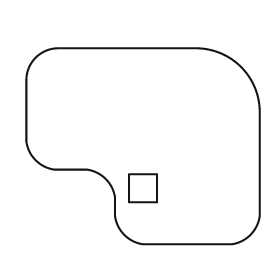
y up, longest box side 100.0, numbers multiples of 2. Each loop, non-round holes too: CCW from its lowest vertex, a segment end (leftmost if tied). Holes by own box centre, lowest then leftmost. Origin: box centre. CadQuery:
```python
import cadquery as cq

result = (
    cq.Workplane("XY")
    .moveTo(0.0, -42.0)
    .lineTo(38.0, -42.0)
    .threePointArc((46.0, -38.0), (50.0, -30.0))
    .lineTo(50.0, 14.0)
    .threePointArc((42.0, 34.0), (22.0, 42.0))
    .lineTo(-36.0, 42.0)
    .threePointArc((-46.0, 38.0), (-50.0, 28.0))
    .lineTo(-50.0, 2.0)
    .threePointArc((-46.0, -6.0), (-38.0, -10.0))
    .lineTo(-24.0, -10.0)
    .threePointArc((-16.0, -14.0), (-12.0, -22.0))
    .lineTo(-12.0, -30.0)
    .threePointArc((-8.0, -38.0), (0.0, -42.0))
    .close()
    .moveTo(-6.0, -24.0)
    .lineTo(6.0, -24.0)
    .lineTo(6.0, -12.0)
    .lineTo(-6.0, -12.0)
    .close()
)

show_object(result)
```